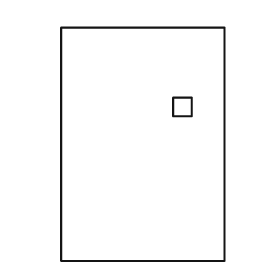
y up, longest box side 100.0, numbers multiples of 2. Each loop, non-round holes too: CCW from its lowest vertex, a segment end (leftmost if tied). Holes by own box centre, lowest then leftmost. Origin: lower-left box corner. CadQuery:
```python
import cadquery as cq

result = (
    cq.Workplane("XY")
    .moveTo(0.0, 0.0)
    .lineTo(70.0, 0.0)
    .lineTo(70.0, 100.0)
    .lineTo(0.0, 100.0)
    .close()
    .moveTo(48.0, 62.0)
    .lineTo(56.0, 62.0)
    .lineTo(56.0, 70.0)
    .lineTo(48.0, 70.0)
    .close()
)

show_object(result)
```